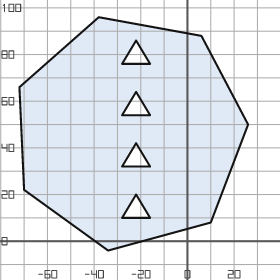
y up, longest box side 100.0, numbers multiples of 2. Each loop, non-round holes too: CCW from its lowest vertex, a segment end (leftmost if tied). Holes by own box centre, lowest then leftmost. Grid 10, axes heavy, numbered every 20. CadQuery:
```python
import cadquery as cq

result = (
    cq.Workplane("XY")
    .moveTo(-34.0, -4.0)
    .lineTo(10.0, 8.0)
    .lineTo(26.0, 50.0)
    .lineTo(6.0, 88.0)
    .lineTo(-38.0, 96.0)
    .lineTo(-72.0, 66.0)
    .lineTo(-70.0, 22.0)
    .close()
    .moveTo(-28.0, 10.0)
    .lineTo(-16.0, 10.0)
    .lineTo(-22.0, 20.0)
    .close()
    .moveTo(-28.0, 32.0)
    .lineTo(-16.0, 32.0)
    .lineTo(-22.0, 42.0)
    .close()
    .moveTo(-28.0, 54.0)
    .lineTo(-16.0, 54.0)
    .lineTo(-22.0, 64.0)
    .close()
    .moveTo(-28.0, 76.0)
    .lineTo(-16.0, 76.0)
    .lineTo(-22.0, 86.0)
    .close()
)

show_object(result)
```